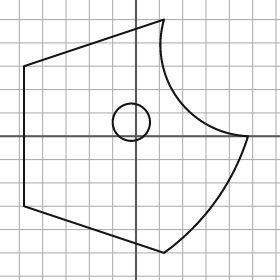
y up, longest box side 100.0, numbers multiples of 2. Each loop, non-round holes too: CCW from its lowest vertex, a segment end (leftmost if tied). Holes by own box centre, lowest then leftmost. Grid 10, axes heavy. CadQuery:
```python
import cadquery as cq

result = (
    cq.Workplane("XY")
    .moveTo(12.0, -50.0)
    .threePointArc((34.0, -28.0), (48.0, 0.0))
    .threePointArc((18.0, 16.0), (12.0, 50.0))
    .lineTo(-48.0, 30.0)
    .lineTo(-48.0, -30.0)
    .close()
    .moveTo(-2.0, 6.0)
    .circle(8.0)
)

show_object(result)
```